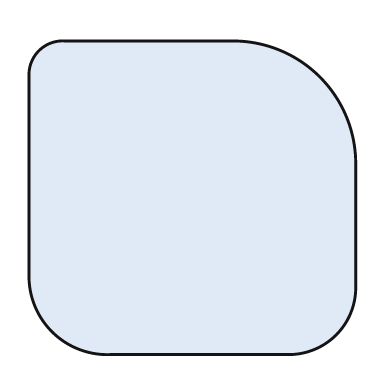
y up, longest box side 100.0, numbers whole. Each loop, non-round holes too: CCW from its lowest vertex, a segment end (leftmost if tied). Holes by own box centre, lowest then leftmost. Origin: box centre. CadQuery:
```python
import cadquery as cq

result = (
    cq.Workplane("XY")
    .moveTo(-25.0, -48.0)
    .lineTo(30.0, -48.0)
    .threePointArc((44.0, -42.0), (50.0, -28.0))
    .lineTo(50.0, 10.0)
    .threePointArc((39.0, 37.0), (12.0, 48.0))
    .lineTo(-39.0, 48.0)
    .threePointArc((-47.0, 45.0), (-50.0, 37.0))
    .lineTo(-50.0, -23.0)
    .threePointArc((-43.0, -41.0), (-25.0, -48.0))
    .close()
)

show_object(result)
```